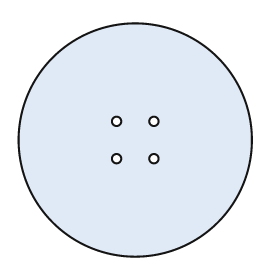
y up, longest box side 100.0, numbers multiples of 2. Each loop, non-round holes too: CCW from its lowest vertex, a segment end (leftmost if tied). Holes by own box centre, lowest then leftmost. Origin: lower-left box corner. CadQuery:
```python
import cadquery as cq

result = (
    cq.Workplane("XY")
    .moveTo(50.0, 50.0)
    .circle(50.0)
    .moveTo(42.0, 42.0)
    .circle(2.0)
    .moveTo(58.0, 42.0)
    .circle(2.0)
    .moveTo(42.0, 58.0)
    .circle(2.0)
    .moveTo(58.0, 58.0)
    .circle(2.0)
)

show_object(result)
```